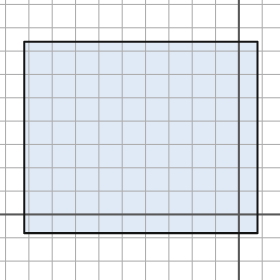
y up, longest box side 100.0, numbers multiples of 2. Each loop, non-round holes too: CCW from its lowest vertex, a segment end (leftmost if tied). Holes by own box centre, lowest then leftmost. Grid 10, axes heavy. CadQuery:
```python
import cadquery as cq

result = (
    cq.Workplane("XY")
    .moveTo(-92.0, -8.0)
    .lineTo(8.0, -8.0)
    .lineTo(8.0, 74.0)
    .lineTo(-92.0, 74.0)
    .close()
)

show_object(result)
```